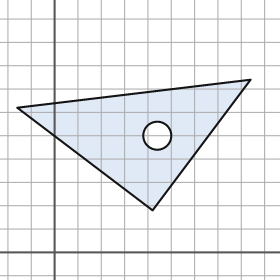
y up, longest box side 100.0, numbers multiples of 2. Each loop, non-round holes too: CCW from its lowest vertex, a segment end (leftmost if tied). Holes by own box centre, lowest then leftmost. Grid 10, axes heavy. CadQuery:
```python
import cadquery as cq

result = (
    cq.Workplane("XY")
    .moveTo(42.0, 18.0)
    .lineTo(84.0, 74.0)
    .lineTo(-16.0, 62.0)
    .close()
    .moveTo(44.0, 50.0)
    .circle(6.0)
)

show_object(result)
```